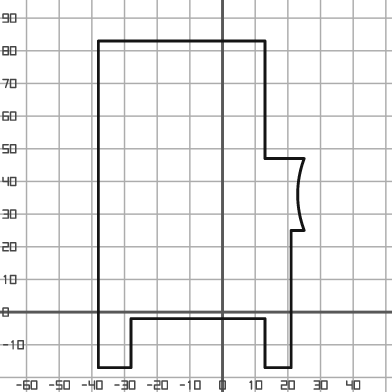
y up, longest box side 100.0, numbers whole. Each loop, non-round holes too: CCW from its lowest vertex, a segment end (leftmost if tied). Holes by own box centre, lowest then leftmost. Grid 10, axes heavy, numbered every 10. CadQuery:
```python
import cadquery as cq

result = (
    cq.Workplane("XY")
    .moveTo(-38.0, -17.0)
    .lineTo(-28.0, -17.0)
    .lineTo(-28.0, -2.0)
    .lineTo(13.0, -2.0)
    .lineTo(13.0, -17.0)
    .lineTo(21.0, -17.0)
    .lineTo(21.0, 25.0)
    .lineTo(25.0, 25.0)
    .threePointArc((23.0, 36.0), (25.0, 47.0))
    .lineTo(13.0, 47.0)
    .lineTo(13.0, 83.0)
    .lineTo(-38.0, 83.0)
    .close()
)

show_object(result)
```